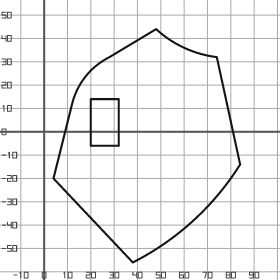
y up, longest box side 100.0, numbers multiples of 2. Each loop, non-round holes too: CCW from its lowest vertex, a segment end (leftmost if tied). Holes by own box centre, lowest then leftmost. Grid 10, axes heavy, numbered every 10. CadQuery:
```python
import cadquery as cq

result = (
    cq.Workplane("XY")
    .moveTo(38.0, -56.0)
    .threePointArc((64.0, -38.0), (84.0, -14.0))
    .lineTo(74.0, 32.0)
    .threePointArc((60.0, 36.0), (48.0, 44.0))
    .lineTo(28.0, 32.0)
    .threePointArc((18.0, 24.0), (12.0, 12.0))
    .lineTo(4.0, -20.0)
    .close()
    .moveTo(20.0, -6.0)
    .lineTo(32.0, -6.0)
    .lineTo(32.0, 14.0)
    .lineTo(20.0, 14.0)
    .close()
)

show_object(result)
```